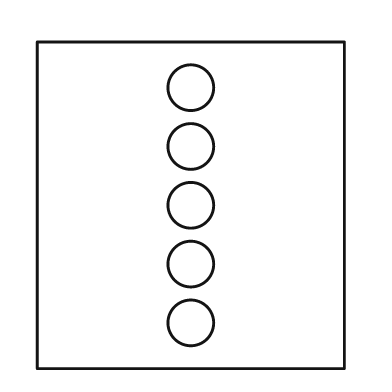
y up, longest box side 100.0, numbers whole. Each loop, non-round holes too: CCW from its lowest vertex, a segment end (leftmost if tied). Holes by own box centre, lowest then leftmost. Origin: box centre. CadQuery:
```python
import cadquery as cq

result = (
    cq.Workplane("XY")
    .moveTo(-47.0, -50.0)
    .lineTo(47.0, -50.0)
    .lineTo(47.0, 50.0)
    .lineTo(-47.0, 50.0)
    .close()
    .moveTo(0.0, -36.0)
    .circle(7.0)
    .moveTo(0.0, -18.0)
    .circle(7.0)
    .moveTo(0.0, 0.0)
    .circle(7.0)
    .moveTo(0.0, 18.0)
    .circle(7.0)
    .moveTo(0.0, 36.0)
    .circle(7.0)
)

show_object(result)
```